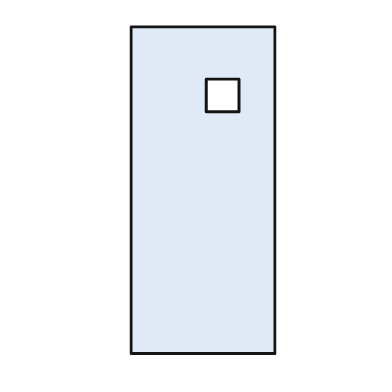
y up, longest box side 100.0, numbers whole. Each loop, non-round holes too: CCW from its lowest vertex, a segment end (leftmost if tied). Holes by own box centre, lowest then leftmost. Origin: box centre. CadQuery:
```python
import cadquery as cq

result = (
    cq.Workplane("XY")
    .moveTo(-22.0, -50.0)
    .lineTo(22.0, -50.0)
    .lineTo(22.0, 50.0)
    .lineTo(-22.0, 50.0)
    .close()
    .moveTo(1.0, 24.0)
    .lineTo(11.0, 24.0)
    .lineTo(11.0, 34.0)
    .lineTo(1.0, 34.0)
    .close()
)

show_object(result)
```